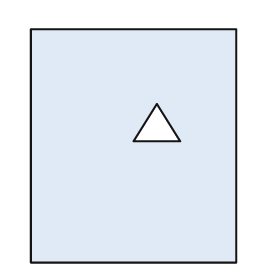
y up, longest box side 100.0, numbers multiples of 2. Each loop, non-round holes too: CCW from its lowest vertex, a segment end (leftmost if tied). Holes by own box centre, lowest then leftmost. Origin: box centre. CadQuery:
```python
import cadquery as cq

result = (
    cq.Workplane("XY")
    .moveTo(-44.0, -50.0)
    .lineTo(44.0, -50.0)
    .lineTo(44.0, 50.0)
    .lineTo(-44.0, 50.0)
    .close()
    .moveTo(0.0, 2.0)
    .lineTo(20.0, 2.0)
    .lineTo(10.0, 18.0)
    .close()
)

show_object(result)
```